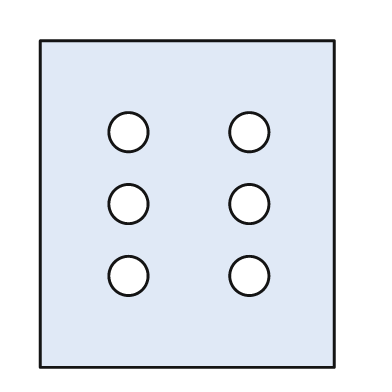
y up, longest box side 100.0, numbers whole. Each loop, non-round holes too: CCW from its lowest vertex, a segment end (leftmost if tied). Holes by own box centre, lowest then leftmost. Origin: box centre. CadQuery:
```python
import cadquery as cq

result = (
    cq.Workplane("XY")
    .moveTo(-45.0, -50.0)
    .lineTo(45.0, -50.0)
    .lineTo(45.0, 50.0)
    .lineTo(-45.0, 50.0)
    .close()
    .moveTo(-18.0, -22.0)
    .circle(6.0)
    .moveTo(19.0, -22.0)
    .circle(6.0)
    .moveTo(-18.0, 0.0)
    .circle(6.0)
    .moveTo(19.0, 0.0)
    .circle(6.0)
    .moveTo(-18.0, 22.0)
    .circle(6.0)
    .moveTo(19.0, 22.0)
    .circle(6.0)
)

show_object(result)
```